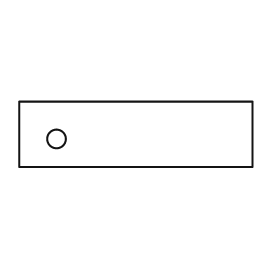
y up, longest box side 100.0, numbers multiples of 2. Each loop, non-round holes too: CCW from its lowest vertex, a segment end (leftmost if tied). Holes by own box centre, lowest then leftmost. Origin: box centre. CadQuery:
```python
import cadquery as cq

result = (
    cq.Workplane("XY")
    .moveTo(-50.0, -14.0)
    .lineTo(50.0, -14.0)
    .lineTo(50.0, 14.0)
    .lineTo(-50.0, 14.0)
    .close()
    .moveTo(-34.0, -2.0)
    .circle(4.0)
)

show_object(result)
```